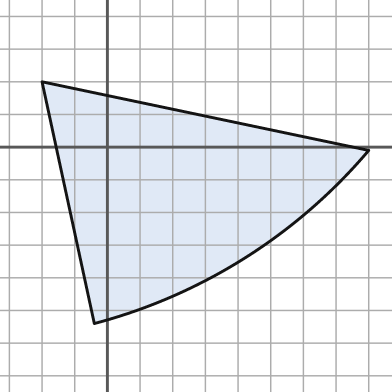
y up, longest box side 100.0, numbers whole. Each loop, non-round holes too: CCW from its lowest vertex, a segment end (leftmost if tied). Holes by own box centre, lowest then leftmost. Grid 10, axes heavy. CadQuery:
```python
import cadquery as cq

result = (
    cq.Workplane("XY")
    .moveTo(-4.0, -54.0)
    .threePointArc((42.0, -34.0), (80.0, -1.0))
    .lineTo(-20.0, 20.0)
    .close()
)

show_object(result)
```